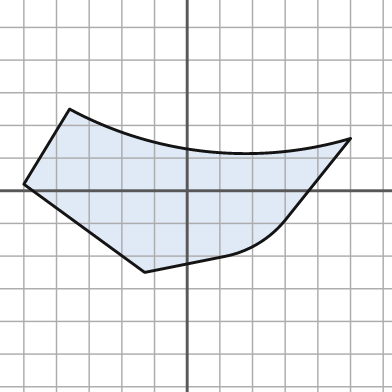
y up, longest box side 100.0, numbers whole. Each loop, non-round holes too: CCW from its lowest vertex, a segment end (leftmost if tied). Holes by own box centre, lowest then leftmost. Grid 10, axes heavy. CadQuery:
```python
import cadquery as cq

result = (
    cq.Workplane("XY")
    .moveTo(-13.0, -25.0)
    .lineTo(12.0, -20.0)
    .threePointArc((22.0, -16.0), (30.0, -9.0))
    .lineTo(50.0, 16.0)
    .threePointArc((6.0, 12.0), (-36.0, 25.0))
    .lineTo(-50.0, 2.0)
    .close()
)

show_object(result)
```